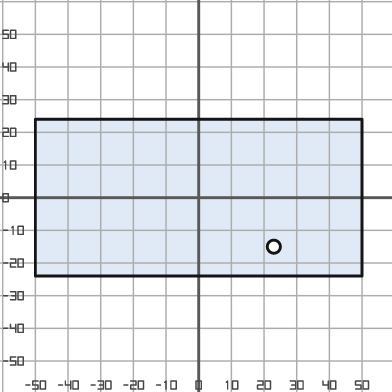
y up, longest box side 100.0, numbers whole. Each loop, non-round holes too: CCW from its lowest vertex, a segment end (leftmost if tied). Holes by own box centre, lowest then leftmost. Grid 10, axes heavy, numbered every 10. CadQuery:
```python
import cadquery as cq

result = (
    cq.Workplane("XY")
    .moveTo(-50.0, -24.0)
    .lineTo(50.0, -24.0)
    .lineTo(50.0, 24.0)
    .lineTo(-50.0, 24.0)
    .close()
    .moveTo(23.0, -15.0)
    .circle(2.0)
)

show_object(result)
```